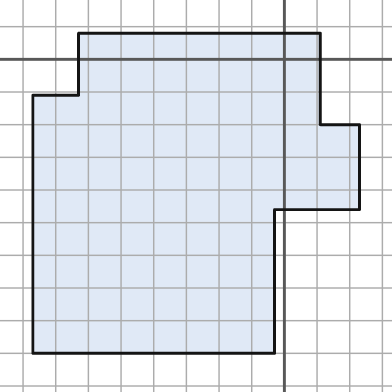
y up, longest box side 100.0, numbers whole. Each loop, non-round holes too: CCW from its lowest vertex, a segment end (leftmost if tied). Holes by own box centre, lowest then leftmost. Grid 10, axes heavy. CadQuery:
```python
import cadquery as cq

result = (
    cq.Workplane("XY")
    .moveTo(-77.0, -90.0)
    .lineTo(-3.0, -90.0)
    .lineTo(-3.0, -46.0)
    .lineTo(23.0, -46.0)
    .lineTo(23.0, -20.0)
    .lineTo(11.0, -20.0)
    .lineTo(11.0, 8.0)
    .lineTo(-63.0, 8.0)
    .lineTo(-63.0, -11.0)
    .lineTo(-77.0, -11.0)
    .close()
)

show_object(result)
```